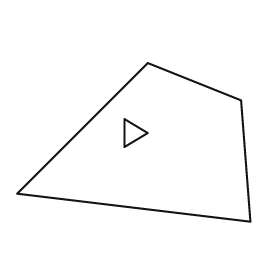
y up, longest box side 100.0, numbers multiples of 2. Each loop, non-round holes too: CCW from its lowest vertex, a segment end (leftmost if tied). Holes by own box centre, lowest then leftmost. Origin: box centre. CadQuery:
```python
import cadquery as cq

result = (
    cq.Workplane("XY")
    .moveTo(50.0, -34.0)
    .lineTo(46.0, 18.0)
    .lineTo(6.0, 34.0)
    .lineTo(-50.0, -22.0)
    .close()
    .moveTo(-4.0, -2.0)
    .lineTo(6.0, 4.0)
    .lineTo(-4.0, 10.0)
    .close()
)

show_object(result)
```